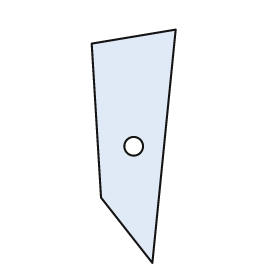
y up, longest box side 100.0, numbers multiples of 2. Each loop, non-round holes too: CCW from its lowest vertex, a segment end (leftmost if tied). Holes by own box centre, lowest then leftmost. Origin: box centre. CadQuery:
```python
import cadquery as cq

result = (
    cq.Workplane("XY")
    .moveTo(8.0, -50.0)
    .lineTo(18.0, 50.0)
    .lineTo(-18.0, 44.0)
    .lineTo(-14.0, -22.0)
    .close()
    .moveTo(0.0, 0.0)
    .circle(4.0)
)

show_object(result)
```